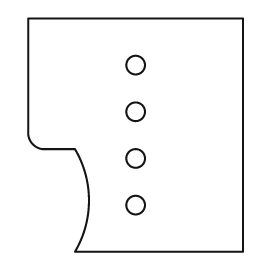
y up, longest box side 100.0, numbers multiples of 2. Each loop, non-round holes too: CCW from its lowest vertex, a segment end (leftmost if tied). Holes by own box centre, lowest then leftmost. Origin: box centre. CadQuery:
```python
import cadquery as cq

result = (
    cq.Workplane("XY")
    .moveTo(-26.0, -50.0)
    .lineTo(46.0, -50.0)
    .lineTo(46.0, 50.0)
    .lineTo(-46.0, 50.0)
    .lineTo(-46.0, 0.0)
    .threePointArc((-44.0, -4.0), (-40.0, -6.0))
    .lineTo(-26.0, -6.0)
    .threePointArc((-20.0, -28.0), (-26.0, -50.0))
    .close()
    .moveTo(0.0, -30.0)
    .circle(4.0)
    .moveTo(0.0, -10.0)
    .circle(4.0)
    .moveTo(0.0, 10.0)
    .circle(4.0)
    .moveTo(0.0, 30.0)
    .circle(4.0)
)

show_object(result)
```